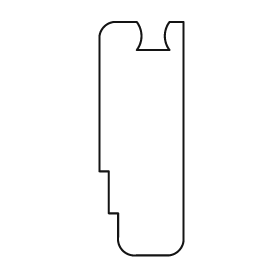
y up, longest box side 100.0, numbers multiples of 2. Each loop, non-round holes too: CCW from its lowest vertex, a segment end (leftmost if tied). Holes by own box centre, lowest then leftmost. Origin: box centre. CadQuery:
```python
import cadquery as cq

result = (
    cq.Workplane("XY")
    .moveTo(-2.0, -50.0)
    .lineTo(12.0, -50.0)
    .threePointArc((16.0, -48.0), (18.0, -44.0))
    .lineTo(18.0, 50.0)
    .lineTo(12.0, 50.0)
    .threePointArc((10.0, 44.0), (12.0, 38.0))
    .lineTo(-2.0, 38.0)
    .threePointArc((0.0, 44.0), (-2.0, 50.0))
    .lineTo(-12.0, 50.0)
    .threePointArc((-16.0, 48.0), (-18.0, 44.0))
    .lineTo(-18.0, -14.0)
    .lineTo(-14.0, -14.0)
    .lineTo(-14.0, -32.0)
    .lineTo(-10.0, -32.0)
    .lineTo(-10.0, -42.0)
    .threePointArc((-8.0, -48.0), (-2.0, -50.0))
    .close()
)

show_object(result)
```